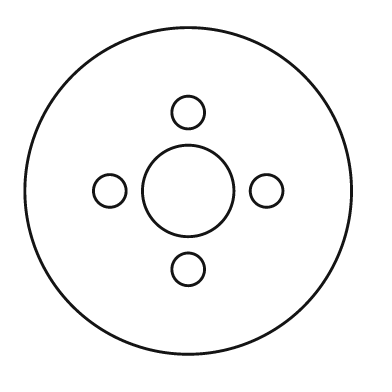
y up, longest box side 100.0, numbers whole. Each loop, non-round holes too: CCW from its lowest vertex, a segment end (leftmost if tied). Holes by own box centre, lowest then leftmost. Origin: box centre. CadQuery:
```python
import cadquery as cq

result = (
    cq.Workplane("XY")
    .moveTo(0.0, 0.0)
    .circle(50.0)
    .moveTo(0.0, -24.0)
    .circle(5.0)
    .moveTo(-24.0, 0.0)
    .circle(5.0)
    .moveTo(0.0, 0.0)
    .circle(14.0)
    .moveTo(24.0, 0.0)
    .circle(5.0)
    .moveTo(0.0, 24.0)
    .circle(5.0)
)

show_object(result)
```